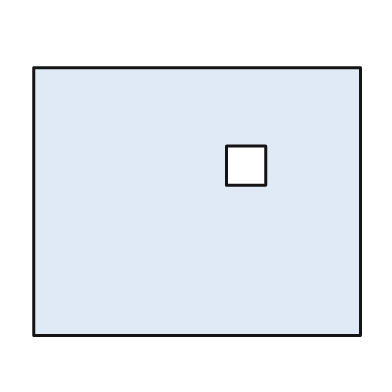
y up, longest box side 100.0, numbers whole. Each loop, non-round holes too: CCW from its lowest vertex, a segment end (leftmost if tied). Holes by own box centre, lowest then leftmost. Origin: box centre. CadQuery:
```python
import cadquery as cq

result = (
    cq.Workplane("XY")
    .moveTo(-50.0, -41.0)
    .lineTo(50.0, -41.0)
    .lineTo(50.0, 41.0)
    .lineTo(-50.0, 41.0)
    .close()
    .moveTo(9.0, 5.0)
    .lineTo(21.0, 5.0)
    .lineTo(21.0, 17.0)
    .lineTo(9.0, 17.0)
    .close()
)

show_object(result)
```